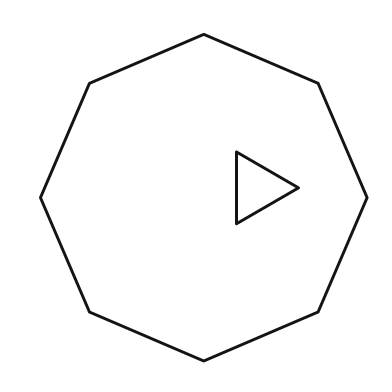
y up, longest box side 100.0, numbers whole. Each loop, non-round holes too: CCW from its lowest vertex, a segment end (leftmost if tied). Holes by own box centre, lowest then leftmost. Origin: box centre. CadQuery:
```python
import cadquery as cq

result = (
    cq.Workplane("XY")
    .moveTo(0.0, -50.0)
    .lineTo(35.0, -35.0)
    .lineTo(50.0, 0.0)
    .lineTo(35.0, 35.0)
    .lineTo(0.0, 50.0)
    .lineTo(-35.0, 35.0)
    .lineTo(-50.0, 0.0)
    .lineTo(-35.0, -35.0)
    .close()
    .moveTo(10.0, -8.0)
    .lineTo(29.0, 3.0)
    .lineTo(10.0, 14.0)
    .close()
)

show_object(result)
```